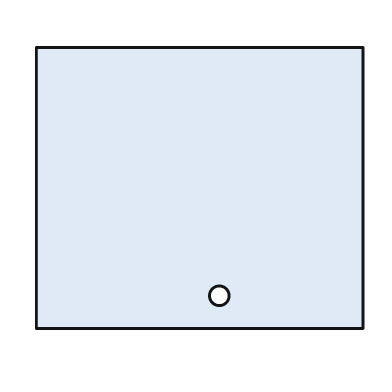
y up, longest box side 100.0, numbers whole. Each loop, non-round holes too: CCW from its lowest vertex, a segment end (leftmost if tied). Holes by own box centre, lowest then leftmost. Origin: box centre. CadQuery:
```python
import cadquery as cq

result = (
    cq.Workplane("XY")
    .moveTo(-50.0, -43.0)
    .lineTo(50.0, -43.0)
    .lineTo(50.0, 43.0)
    .lineTo(-50.0, 43.0)
    .close()
    .moveTo(6.0, -33.0)
    .circle(3.0)
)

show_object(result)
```